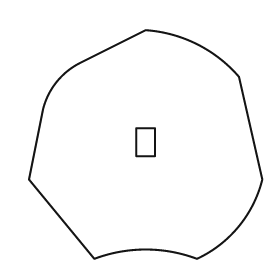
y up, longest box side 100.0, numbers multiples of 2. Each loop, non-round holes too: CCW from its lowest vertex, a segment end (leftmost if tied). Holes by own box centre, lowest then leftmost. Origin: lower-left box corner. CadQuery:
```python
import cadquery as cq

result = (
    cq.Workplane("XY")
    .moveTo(28.0, 0.0)
    .threePointArc((50.0, 4.0), (72.0, 0.0))
    .threePointArc((90.0, 14.0), (100.0, 34.0))
    .lineTo(90.0, 78.0)
    .threePointArc((72.0, 92.0), (50.0, 98.0))
    .lineTo(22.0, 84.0)
    .threePointArc((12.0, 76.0), (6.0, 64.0))
    .lineTo(0.0, 34.0)
    .close()
    .moveTo(46.0, 44.0)
    .lineTo(54.0, 44.0)
    .lineTo(54.0, 56.0)
    .lineTo(46.0, 56.0)
    .close()
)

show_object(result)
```